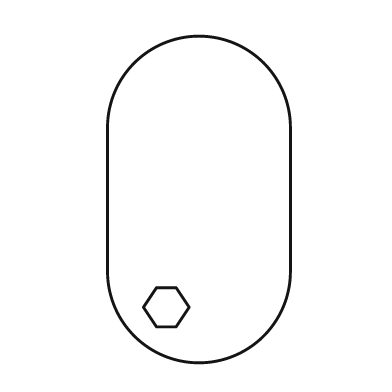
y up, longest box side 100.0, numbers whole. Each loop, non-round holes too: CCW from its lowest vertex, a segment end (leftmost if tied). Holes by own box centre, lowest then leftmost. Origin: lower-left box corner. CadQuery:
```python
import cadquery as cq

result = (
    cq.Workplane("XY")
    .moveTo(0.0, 28.0)
    .threePointArc((28.0, 0.0), (56.0, 28.0))
    .lineTo(56.0, 72.0)
    .threePointArc((28.0, 100.0), (0.0, 72.0))
    .close()
    .moveTo(15.0, 11.0)
    .lineTo(21.0, 11.0)
    .lineTo(25.0, 17.0)
    .lineTo(21.0, 23.0)
    .lineTo(15.0, 23.0)
    .lineTo(11.0, 17.0)
    .close()
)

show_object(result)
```